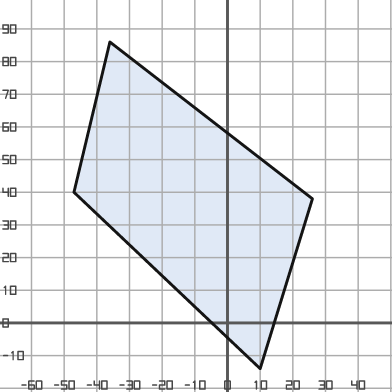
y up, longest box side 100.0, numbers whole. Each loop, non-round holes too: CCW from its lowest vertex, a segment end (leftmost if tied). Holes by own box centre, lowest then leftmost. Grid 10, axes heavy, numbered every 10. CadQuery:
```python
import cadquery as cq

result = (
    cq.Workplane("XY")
    .moveTo(10.0, -14.0)
    .lineTo(26.0, 38.0)
    .lineTo(-36.0, 86.0)
    .lineTo(-47.0, 40.0)
    .close()
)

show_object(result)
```